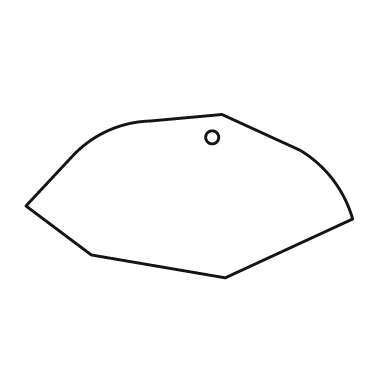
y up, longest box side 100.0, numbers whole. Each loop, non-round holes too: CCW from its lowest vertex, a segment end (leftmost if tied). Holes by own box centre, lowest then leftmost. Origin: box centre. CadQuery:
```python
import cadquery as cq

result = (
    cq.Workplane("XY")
    .moveTo(11.0, -25.0)
    .lineTo(50.0, -7.0)
    .threePointArc((44.0, 5.0), (34.0, 14.0))
    .lineTo(10.0, 25.0)
    .lineTo(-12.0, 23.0)
    .threePointArc((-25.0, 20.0), (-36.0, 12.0))
    .lineTo(-50.0, -3.0)
    .lineTo(-30.0, -18.0)
    .close()
    .moveTo(7.0, 18.0)
    .circle(2.0)
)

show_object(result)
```